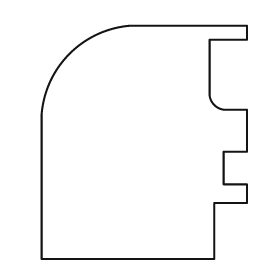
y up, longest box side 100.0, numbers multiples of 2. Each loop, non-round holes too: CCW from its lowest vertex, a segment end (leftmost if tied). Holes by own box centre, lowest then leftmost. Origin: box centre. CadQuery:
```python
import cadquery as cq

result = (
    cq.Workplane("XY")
    .moveTo(-44.0, -50.0)
    .lineTo(30.0, -50.0)
    .lineTo(30.0, -26.0)
    .lineTo(44.0, -26.0)
    .lineTo(44.0, -18.0)
    .lineTo(34.0, -18.0)
    .lineTo(34.0, -4.0)
    .lineTo(44.0, -4.0)
    .lineTo(44.0, 14.0)
    .lineTo(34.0, 14.0)
    .threePointArc((30.0, 16.0), (28.0, 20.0))
    .lineTo(28.0, 44.0)
    .lineTo(44.0, 44.0)
    .lineTo(44.0, 50.0)
    .lineTo(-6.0, 50.0)
    .threePointArc((-32.0, 38.0), (-44.0, 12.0))
    .close()
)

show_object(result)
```